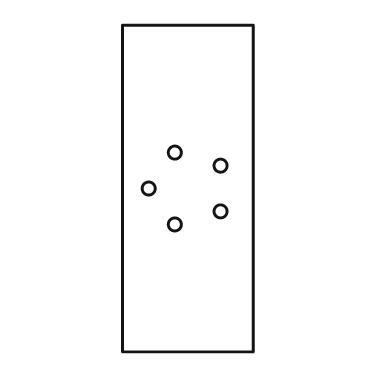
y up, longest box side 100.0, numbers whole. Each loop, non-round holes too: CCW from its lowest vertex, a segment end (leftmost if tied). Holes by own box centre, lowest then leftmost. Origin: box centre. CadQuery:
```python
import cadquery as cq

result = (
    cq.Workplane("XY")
    .moveTo(-20.0, -50.0)
    .lineTo(20.0, -50.0)
    .lineTo(20.0, 50.0)
    .lineTo(-20.0, 50.0)
    .close()
    .moveTo(-4.0, -11.0)
    .circle(2.0)
    .moveTo(10.0, -7.0)
    .circle(2.0)
    .moveTo(-12.0, 0.0)
    .circle(2.0)
    .moveTo(10.0, 7.0)
    .circle(2.0)
    .moveTo(-4.0, 11.0)
    .circle(2.0)
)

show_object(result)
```